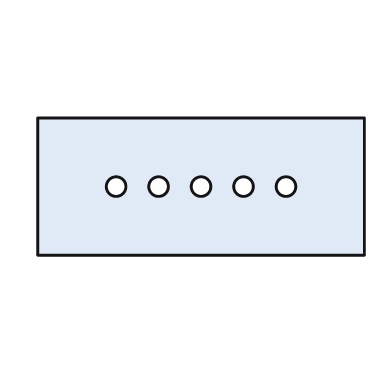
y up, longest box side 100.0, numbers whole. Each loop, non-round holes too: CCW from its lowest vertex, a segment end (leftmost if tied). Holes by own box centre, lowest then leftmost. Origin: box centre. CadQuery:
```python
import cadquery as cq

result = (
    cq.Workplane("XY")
    .moveTo(-50.0, -21.0)
    .lineTo(50.0, -21.0)
    .lineTo(50.0, 21.0)
    .lineTo(-50.0, 21.0)
    .close()
    .moveTo(-26.0, 0.0)
    .circle(3.0)
    .moveTo(-13.0, 0.0)
    .circle(3.0)
    .moveTo(0.0, 0.0)
    .circle(3.0)
    .moveTo(13.0, 0.0)
    .circle(3.0)
    .moveTo(26.0, 0.0)
    .circle(3.0)
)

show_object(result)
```